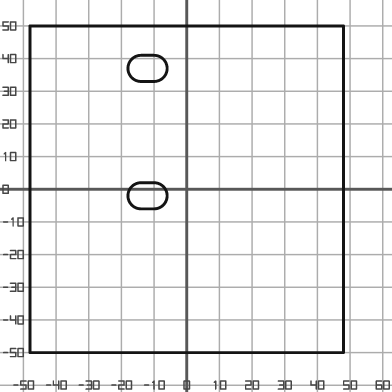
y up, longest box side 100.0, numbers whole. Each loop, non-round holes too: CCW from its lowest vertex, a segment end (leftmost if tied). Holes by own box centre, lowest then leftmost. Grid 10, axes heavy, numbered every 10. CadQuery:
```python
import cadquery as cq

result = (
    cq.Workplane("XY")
    .moveTo(-48.0, -50.0)
    .lineTo(48.0, -50.0)
    .lineTo(48.0, 50.0)
    .lineTo(-48.0, 50.0)
    .close()
    .moveTo(-14.0, -6.0)
    .lineTo(-10.0, -6.0)
    .threePointArc((-6.0, -2.0), (-10.0, 2.0))
    .lineTo(-14.0, 2.0)
    .threePointArc((-18.0, -2.0), (-14.0, -6.0))
    .close()
    .moveTo(-14.0, 33.0)
    .lineTo(-10.0, 33.0)
    .threePointArc((-6.0, 37.0), (-10.0, 41.0))
    .lineTo(-14.0, 41.0)
    .threePointArc((-18.0, 37.0), (-14.0, 33.0))
    .close()
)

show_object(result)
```